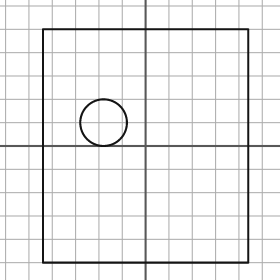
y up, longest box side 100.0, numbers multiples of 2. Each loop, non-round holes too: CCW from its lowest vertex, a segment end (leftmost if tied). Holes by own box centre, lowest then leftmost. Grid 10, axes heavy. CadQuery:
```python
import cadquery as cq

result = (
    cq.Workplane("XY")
    .moveTo(-44.0, -50.0)
    .lineTo(44.0, -50.0)
    .lineTo(44.0, 50.0)
    .lineTo(-44.0, 50.0)
    .close()
    .moveTo(-18.0, 10.0)
    .circle(10.0)
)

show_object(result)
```